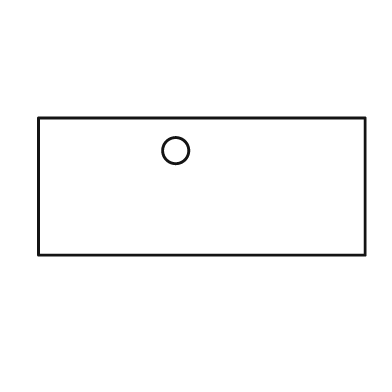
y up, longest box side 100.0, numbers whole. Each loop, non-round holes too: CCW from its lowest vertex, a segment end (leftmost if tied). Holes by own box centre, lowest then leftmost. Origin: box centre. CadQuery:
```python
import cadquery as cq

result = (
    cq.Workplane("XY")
    .moveTo(-50.0, -21.0)
    .lineTo(50.0, -21.0)
    .lineTo(50.0, 21.0)
    .lineTo(-50.0, 21.0)
    .close()
    .moveTo(-8.0, 11.0)
    .circle(4.0)
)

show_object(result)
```